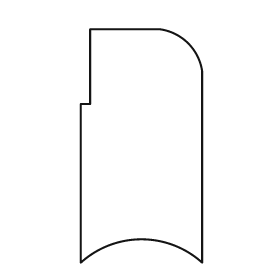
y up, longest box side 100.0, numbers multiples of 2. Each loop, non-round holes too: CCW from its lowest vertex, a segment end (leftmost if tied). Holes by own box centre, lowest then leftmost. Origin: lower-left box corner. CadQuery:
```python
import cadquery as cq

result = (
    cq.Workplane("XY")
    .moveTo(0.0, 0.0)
    .threePointArc((26.0, 10.0), (52.0, 0.0))
    .lineTo(52.0, 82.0)
    .threePointArc((46.0, 94.0), (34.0, 100.0))
    .lineTo(4.0, 100.0)
    .lineTo(4.0, 68.0)
    .lineTo(0.0, 68.0)
    .close()
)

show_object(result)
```